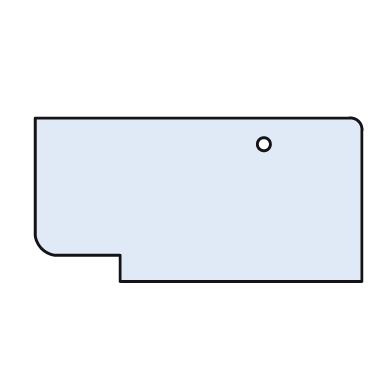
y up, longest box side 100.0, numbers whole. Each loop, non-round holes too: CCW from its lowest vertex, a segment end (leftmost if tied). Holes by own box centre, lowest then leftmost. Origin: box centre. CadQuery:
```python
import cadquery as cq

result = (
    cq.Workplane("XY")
    .moveTo(-24.0, -25.0)
    .lineTo(50.0, -25.0)
    .lineTo(50.0, 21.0)
    .threePointArc((49.0, 24.0), (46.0, 25.0))
    .lineTo(-50.0, 25.0)
    .lineTo(-50.0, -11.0)
    .threePointArc((-48.0, -15.0), (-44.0, -17.0))
    .lineTo(-24.0, -17.0)
    .close()
    .moveTo(20.0, 17.0)
    .circle(2.0)
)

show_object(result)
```